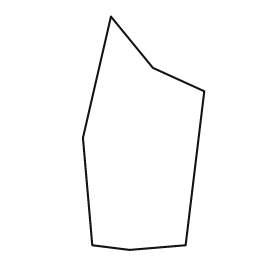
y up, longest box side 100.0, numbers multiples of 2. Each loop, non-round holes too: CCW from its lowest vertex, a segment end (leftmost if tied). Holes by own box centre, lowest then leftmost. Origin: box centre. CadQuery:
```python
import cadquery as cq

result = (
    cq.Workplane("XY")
    .moveTo(-6.0, -50.0)
    .lineTo(18.0, -48.0)
    .lineTo(26.0, 18.0)
    .lineTo(4.0, 28.0)
    .lineTo(-14.0, 50.0)
    .lineTo(-26.0, -2.0)
    .lineTo(-22.0, -48.0)
    .close()
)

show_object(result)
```